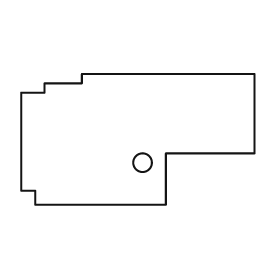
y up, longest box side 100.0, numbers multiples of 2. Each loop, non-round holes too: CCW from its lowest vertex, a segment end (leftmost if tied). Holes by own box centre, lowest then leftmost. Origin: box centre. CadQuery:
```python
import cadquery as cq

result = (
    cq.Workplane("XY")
    .moveTo(-44.0, -28.0)
    .lineTo(12.0, -28.0)
    .lineTo(12.0, -6.0)
    .lineTo(50.0, -6.0)
    .lineTo(50.0, 28.0)
    .lineTo(-24.0, 28.0)
    .lineTo(-24.0, 24.0)
    .lineTo(-40.0, 24.0)
    .lineTo(-40.0, 20.0)
    .lineTo(-50.0, 20.0)
    .lineTo(-50.0, -22.0)
    .lineTo(-44.0, -22.0)
    .close()
    .moveTo(2.0, -10.0)
    .circle(4.0)
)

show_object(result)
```